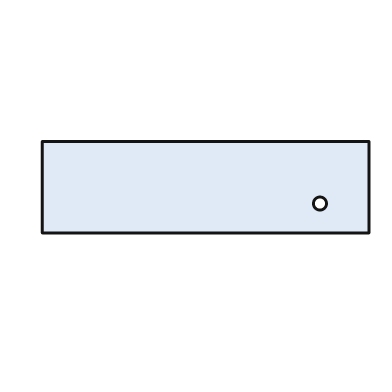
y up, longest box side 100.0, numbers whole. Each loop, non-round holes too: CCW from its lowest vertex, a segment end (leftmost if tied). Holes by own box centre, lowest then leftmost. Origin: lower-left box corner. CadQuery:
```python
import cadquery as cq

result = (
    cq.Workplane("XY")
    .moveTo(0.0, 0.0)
    .lineTo(100.0, 0.0)
    .lineTo(100.0, 28.0)
    .lineTo(0.0, 28.0)
    .close()
    .moveTo(85.0, 9.0)
    .circle(2.0)
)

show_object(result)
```